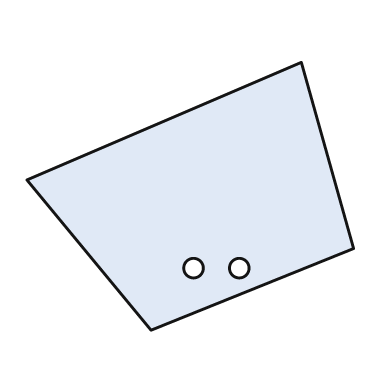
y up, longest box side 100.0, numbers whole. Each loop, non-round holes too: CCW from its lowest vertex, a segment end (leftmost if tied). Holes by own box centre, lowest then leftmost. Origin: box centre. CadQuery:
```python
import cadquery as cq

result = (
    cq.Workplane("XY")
    .moveTo(-12.0, -41.0)
    .lineTo(50.0, -16.0)
    .lineTo(34.0, 41.0)
    .lineTo(-50.0, 5.0)
    .close()
    .moveTo(1.0, -22.0)
    .circle(3.0)
    .moveTo(15.0, -22.0)
    .circle(3.0)
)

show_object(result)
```